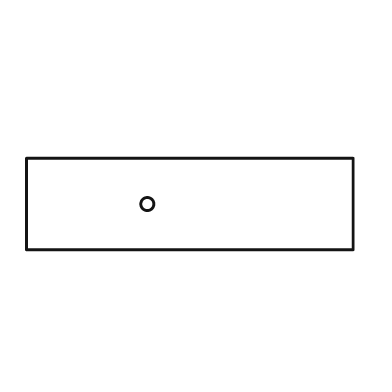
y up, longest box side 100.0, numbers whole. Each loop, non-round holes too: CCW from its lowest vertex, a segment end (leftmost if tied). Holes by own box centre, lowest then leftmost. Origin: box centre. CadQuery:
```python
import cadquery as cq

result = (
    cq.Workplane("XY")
    .moveTo(-50.0, -14.0)
    .lineTo(50.0, -14.0)
    .lineTo(50.0, 14.0)
    .lineTo(-50.0, 14.0)
    .close()
    .moveTo(-13.0, 0.0)
    .circle(2.0)
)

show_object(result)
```